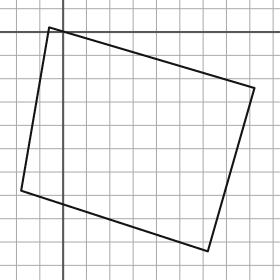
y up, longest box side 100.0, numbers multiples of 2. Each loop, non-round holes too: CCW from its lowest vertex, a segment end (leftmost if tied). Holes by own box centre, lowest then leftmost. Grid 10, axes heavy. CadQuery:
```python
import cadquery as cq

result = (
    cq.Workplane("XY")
    .moveTo(62.0, -94.0)
    .lineTo(82.0, -24.0)
    .lineTo(-6.0, 2.0)
    .lineTo(-18.0, -68.0)
    .close()
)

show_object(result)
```